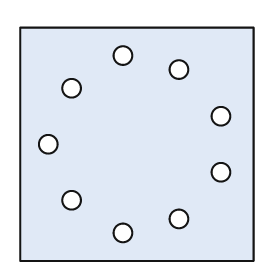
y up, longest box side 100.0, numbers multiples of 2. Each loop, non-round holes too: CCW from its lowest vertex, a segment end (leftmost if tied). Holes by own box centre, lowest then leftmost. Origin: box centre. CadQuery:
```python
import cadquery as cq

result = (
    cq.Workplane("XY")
    .moveTo(-50.0, -50.0)
    .lineTo(50.0, -50.0)
    .lineTo(50.0, 50.0)
    .lineTo(-50.0, 50.0)
    .close()
    .moveTo(-6.0, -38.0)
    .circle(4.0)
    .moveTo(18.0, -32.0)
    .circle(4.0)
    .moveTo(-28.0, -24.0)
    .circle(4.0)
    .moveTo(36.0, -12.0)
    .circle(4.0)
    .moveTo(-38.0, 0.0)
    .circle(4.0)
    .moveTo(36.0, 12.0)
    .circle(4.0)
    .moveTo(-28.0, 24.0)
    .circle(4.0)
    .moveTo(18.0, 32.0)
    .circle(4.0)
    .moveTo(-6.0, 38.0)
    .circle(4.0)
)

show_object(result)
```